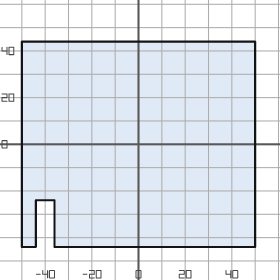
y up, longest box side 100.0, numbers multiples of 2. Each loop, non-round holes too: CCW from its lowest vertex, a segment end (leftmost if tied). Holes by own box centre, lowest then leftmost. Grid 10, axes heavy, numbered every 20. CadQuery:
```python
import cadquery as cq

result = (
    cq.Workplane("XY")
    .moveTo(-50.0, -44.0)
    .lineTo(-44.0, -44.0)
    .lineTo(-44.0, -24.0)
    .lineTo(-36.0, -24.0)
    .lineTo(-36.0, -44.0)
    .lineTo(50.0, -44.0)
    .lineTo(50.0, 44.0)
    .lineTo(-50.0, 44.0)
    .close()
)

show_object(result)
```